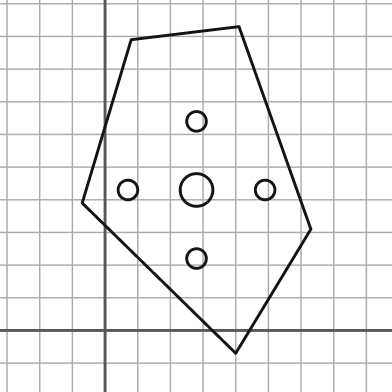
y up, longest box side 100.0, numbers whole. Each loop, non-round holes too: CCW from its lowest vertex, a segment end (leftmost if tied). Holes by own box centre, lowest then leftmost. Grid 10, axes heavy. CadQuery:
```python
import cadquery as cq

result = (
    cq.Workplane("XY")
    .moveTo(40.0, -7.0)
    .lineTo(63.0, 31.0)
    .lineTo(41.0, 93.0)
    .lineTo(8.0, 89.0)
    .lineTo(-7.0, 39.0)
    .close()
    .moveTo(28.0, 22.0)
    .circle(3.0)
    .moveTo(7.0, 43.0)
    .circle(3.0)
    .moveTo(28.0, 43.0)
    .circle(5.0)
    .moveTo(49.0, 43.0)
    .circle(3.0)
    .moveTo(28.0, 64.0)
    .circle(3.0)
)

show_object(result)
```